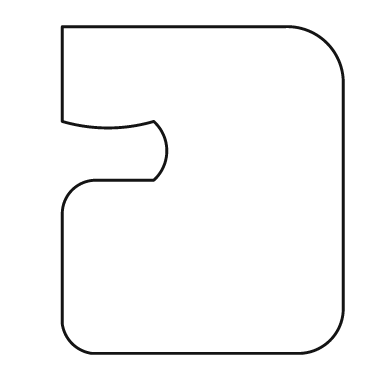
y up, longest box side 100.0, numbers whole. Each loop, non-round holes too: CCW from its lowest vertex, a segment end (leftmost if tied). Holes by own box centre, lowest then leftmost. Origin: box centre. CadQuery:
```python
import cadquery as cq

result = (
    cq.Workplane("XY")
    .moveTo(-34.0, -50.0)
    .lineTo(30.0, -50.0)
    .threePointArc((39.0, -46.0), (43.0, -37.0))
    .lineTo(43.0, 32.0)
    .threePointArc((38.0, 45.0), (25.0, 50.0))
    .lineTo(-43.0, 50.0)
    .lineTo(-43.0, 21.0)
    .threePointArc((-29.0, 19.0), (-15.0, 21.0))
    .threePointArc((-11.0, 12.0), (-15.0, 3.0))
    .lineTo(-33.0, 3.0)
    .threePointArc((-40.0, 0.0), (-43.0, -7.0))
    .lineTo(-43.0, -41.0)
    .threePointArc((-40.0, -47.0), (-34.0, -50.0))
    .close()
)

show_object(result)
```